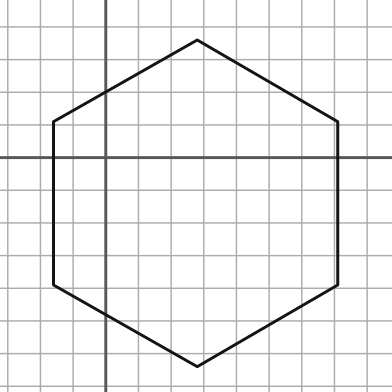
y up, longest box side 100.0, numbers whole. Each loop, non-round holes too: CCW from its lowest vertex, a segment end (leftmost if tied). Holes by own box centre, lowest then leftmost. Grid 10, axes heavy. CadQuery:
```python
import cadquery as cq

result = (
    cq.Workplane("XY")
    .moveTo(28.0, -64.0)
    .lineTo(71.0, -39.0)
    .lineTo(71.0, 11.0)
    .lineTo(28.0, 36.0)
    .lineTo(-16.0, 11.0)
    .lineTo(-16.0, -39.0)
    .close()
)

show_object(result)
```